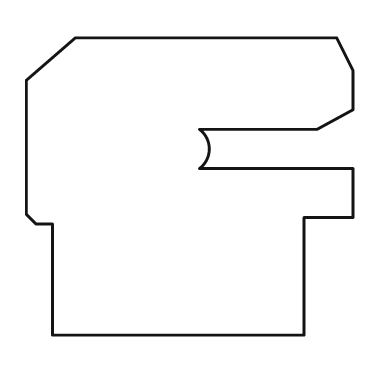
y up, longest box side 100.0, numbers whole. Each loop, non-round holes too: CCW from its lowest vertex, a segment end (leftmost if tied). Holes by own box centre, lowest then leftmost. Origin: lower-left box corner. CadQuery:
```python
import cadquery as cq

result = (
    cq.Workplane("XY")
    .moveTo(8.0, 0.0)
    .lineTo(85.0, 0.0)
    .lineTo(85.0, 36.0)
    .lineTo(100.0, 36.0)
    .lineTo(100.0, 51.0)
    .lineTo(53.0, 51.0)
    .threePointArc((56.0, 57.0), (53.0, 63.0))
    .lineTo(89.0, 63.0)
    .lineTo(100.0, 69.0)
    .lineTo(100.0, 81.0)
    .lineTo(95.0, 91.0)
    .lineTo(15.0, 91.0)
    .lineTo(0.0, 78.0)
    .lineTo(0.0, 37.0)
    .lineTo(3.0, 34.0)
    .lineTo(8.0, 34.0)
    .close()
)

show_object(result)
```